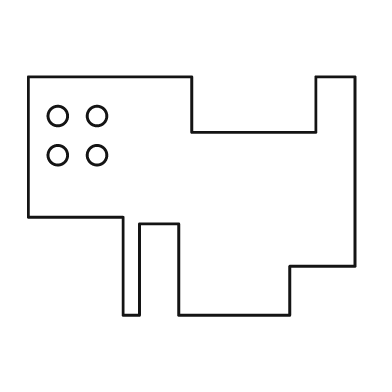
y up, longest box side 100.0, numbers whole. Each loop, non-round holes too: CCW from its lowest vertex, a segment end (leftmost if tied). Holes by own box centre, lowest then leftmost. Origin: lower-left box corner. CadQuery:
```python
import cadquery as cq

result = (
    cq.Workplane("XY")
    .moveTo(29.0, 0.0)
    .lineTo(34.0, 0.0)
    .lineTo(34.0, 28.0)
    .lineTo(46.0, 28.0)
    .lineTo(46.0, 0.0)
    .lineTo(80.0, 0.0)
    .lineTo(80.0, 15.0)
    .lineTo(100.0, 15.0)
    .lineTo(100.0, 73.0)
    .lineTo(88.0, 73.0)
    .lineTo(88.0, 56.0)
    .lineTo(50.0, 56.0)
    .lineTo(50.0, 73.0)
    .lineTo(0.0, 73.0)
    .lineTo(0.0, 30.0)
    .lineTo(29.0, 30.0)
    .close()
    .moveTo(9.0, 49.0)
    .circle(3.0)
    .moveTo(21.0, 49.0)
    .circle(3.0)
    .moveTo(9.0, 61.0)
    .circle(3.0)
    .moveTo(21.0, 61.0)
    .circle(3.0)
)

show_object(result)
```